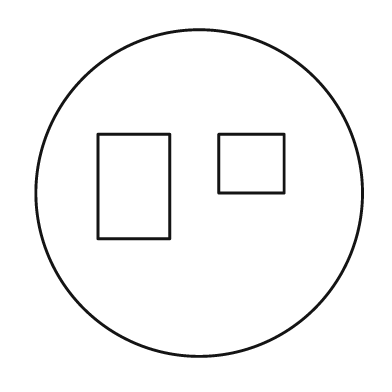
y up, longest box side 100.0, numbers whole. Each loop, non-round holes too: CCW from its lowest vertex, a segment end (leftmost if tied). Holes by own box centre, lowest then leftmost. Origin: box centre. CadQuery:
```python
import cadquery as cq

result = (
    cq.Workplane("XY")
    .moveTo(0.0, 0.0)
    .circle(50.0)
    .moveTo(-31.0, -14.0)
    .lineTo(-9.0, -14.0)
    .lineTo(-9.0, 18.0)
    .lineTo(-31.0, 18.0)
    .close()
    .moveTo(6.0, 0.0)
    .lineTo(26.0, 0.0)
    .lineTo(26.0, 18.0)
    .lineTo(6.0, 18.0)
    .close()
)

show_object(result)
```